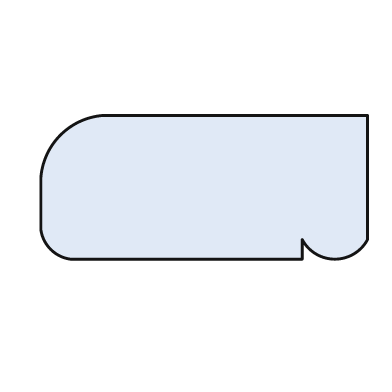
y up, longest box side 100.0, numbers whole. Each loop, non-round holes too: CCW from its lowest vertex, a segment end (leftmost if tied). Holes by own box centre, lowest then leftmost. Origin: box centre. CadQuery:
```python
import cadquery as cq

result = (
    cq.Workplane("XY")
    .moveTo(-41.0, -22.0)
    .lineTo(30.0, -22.0)
    .lineTo(30.0, -16.0)
    .threePointArc((40.0, -22.0), (50.0, -16.0))
    .lineTo(50.0, 22.0)
    .lineTo(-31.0, 22.0)
    .threePointArc((-44.0, 16.0), (-50.0, 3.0))
    .lineTo(-50.0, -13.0)
    .threePointArc((-47.0, -19.0), (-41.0, -22.0))
    .close()
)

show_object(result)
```